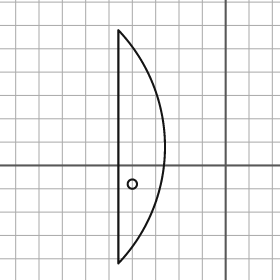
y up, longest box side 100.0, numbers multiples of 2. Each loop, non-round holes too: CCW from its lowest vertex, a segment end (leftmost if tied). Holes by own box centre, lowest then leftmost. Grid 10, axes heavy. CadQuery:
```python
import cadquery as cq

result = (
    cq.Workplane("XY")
    .moveTo(-46.0, -42.0)
    .threePointArc((-26.0, 8.0), (-46.0, 58.0))
    .close()
    .moveTo(-40.0, -8.0)
    .circle(2.0)
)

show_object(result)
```